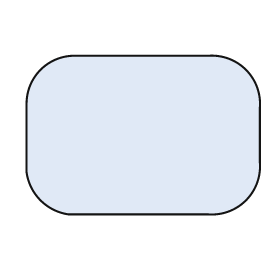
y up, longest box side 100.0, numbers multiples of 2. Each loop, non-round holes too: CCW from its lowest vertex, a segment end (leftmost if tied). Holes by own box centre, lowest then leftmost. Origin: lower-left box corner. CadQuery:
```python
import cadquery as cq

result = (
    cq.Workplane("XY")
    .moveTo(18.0, 0.0)
    .lineTo(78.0, 0.0)
    .threePointArc((94.0, 6.0), (100.0, 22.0))
    .lineTo(100.0, 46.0)
    .threePointArc((94.0, 62.0), (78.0, 68.0))
    .lineTo(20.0, 68.0)
    .threePointArc((6.0, 62.0), (0.0, 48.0))
    .lineTo(0.0, 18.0)
    .threePointArc((6.0, 6.0), (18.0, 0.0))
    .close()
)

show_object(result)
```